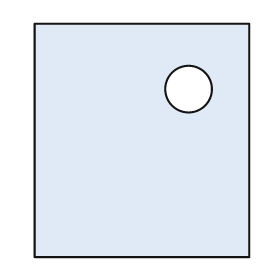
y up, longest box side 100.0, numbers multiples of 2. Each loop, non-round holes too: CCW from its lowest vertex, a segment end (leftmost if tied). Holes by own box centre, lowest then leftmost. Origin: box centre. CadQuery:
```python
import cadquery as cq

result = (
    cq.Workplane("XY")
    .moveTo(-46.0, -50.0)
    .lineTo(46.0, -50.0)
    .lineTo(46.0, 50.0)
    .lineTo(-46.0, 50.0)
    .close()
    .moveTo(20.0, 22.0)
    .circle(10.0)
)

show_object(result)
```